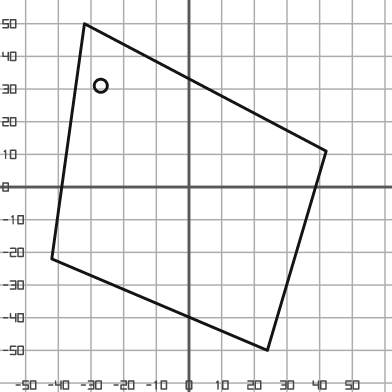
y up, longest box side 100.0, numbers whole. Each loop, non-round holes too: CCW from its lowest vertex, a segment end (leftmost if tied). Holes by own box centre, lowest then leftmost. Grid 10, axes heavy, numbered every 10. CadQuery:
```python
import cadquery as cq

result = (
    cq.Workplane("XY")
    .moveTo(24.0, -50.0)
    .lineTo(42.0, 11.0)
    .lineTo(-32.0, 50.0)
    .lineTo(-42.0, -22.0)
    .close()
    .moveTo(-27.0, 31.0)
    .circle(2.0)
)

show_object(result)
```